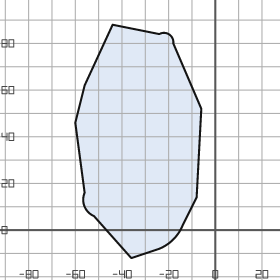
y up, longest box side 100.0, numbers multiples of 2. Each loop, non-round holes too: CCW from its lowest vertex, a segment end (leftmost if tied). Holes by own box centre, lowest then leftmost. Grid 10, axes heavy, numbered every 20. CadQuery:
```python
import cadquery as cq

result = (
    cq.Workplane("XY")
    .moveTo(-36.0, -12.0)
    .lineTo(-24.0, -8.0)
    .threePointArc((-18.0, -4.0), (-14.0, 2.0))
    .lineTo(-8.0, 14.0)
    .lineTo(-6.0, 52.0)
    .lineTo(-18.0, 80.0)
    .threePointArc((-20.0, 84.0), (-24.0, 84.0))
    .lineTo(-44.0, 88.0)
    .lineTo(-56.0, 62.0)
    .lineTo(-60.0, 46.0)
    .lineTo(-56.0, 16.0)
    .threePointArc((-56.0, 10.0), (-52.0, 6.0))
    .close()
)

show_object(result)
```